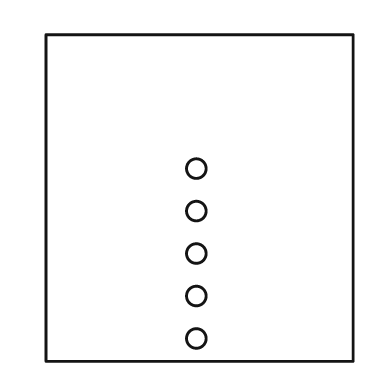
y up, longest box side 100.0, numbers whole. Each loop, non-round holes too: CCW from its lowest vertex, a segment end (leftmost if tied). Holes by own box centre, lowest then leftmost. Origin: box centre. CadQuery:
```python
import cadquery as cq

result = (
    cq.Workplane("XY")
    .moveTo(-47.0, -50.0)
    .lineTo(47.0, -50.0)
    .lineTo(47.0, 50.0)
    .lineTo(-47.0, 50.0)
    .close()
    .moveTo(-1.0, -43.0)
    .circle(3.0)
    .moveTo(-1.0, -30.0)
    .circle(3.0)
    .moveTo(-1.0, -17.0)
    .circle(3.0)
    .moveTo(-1.0, -4.0)
    .circle(3.0)
    .moveTo(-1.0, 9.0)
    .circle(3.0)
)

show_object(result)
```